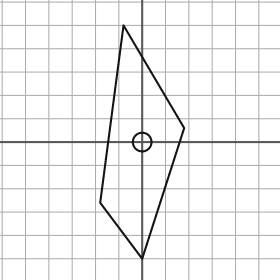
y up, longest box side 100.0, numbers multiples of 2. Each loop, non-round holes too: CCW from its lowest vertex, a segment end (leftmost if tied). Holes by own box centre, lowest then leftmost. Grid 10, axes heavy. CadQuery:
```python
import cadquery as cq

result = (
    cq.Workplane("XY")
    .moveTo(0.0, -50.0)
    .lineTo(18.0, 6.0)
    .lineTo(-8.0, 50.0)
    .lineTo(-18.0, -26.0)
    .close()
    .moveTo(0.0, 0.0)
    .circle(4.0)
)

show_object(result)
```